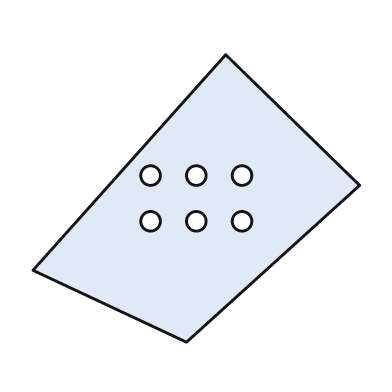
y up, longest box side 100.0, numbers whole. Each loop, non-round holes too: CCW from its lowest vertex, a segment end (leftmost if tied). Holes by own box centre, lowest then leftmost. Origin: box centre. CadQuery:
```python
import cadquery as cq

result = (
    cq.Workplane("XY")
    .moveTo(-3.0, -44.0)
    .lineTo(50.0, 4.0)
    .lineTo(9.0, 44.0)
    .lineTo(-50.0, -22.0)
    .close()
    .moveTo(-14.0, -7.0)
    .circle(3.0)
    .moveTo(0.0, -7.0)
    .circle(3.0)
    .moveTo(14.0, -7.0)
    .circle(3.0)
    .moveTo(-14.0, 7.0)
    .circle(3.0)
    .moveTo(0.0, 7.0)
    .circle(3.0)
    .moveTo(14.0, 7.0)
    .circle(3.0)
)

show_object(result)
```